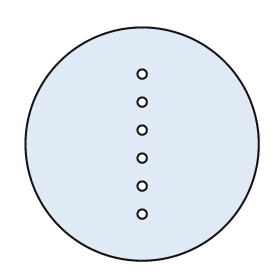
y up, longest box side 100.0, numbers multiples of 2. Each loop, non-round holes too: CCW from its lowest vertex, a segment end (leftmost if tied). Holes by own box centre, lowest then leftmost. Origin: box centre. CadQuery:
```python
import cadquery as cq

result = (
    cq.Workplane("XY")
    .moveTo(0.0, 0.0)
    .circle(50.0)
    .moveTo(0.0, -30.0)
    .circle(2.0)
    .moveTo(0.0, -18.0)
    .circle(2.0)
    .moveTo(0.0, -6.0)
    .circle(2.0)
    .moveTo(0.0, 6.0)
    .circle(2.0)
    .moveTo(0.0, 18.0)
    .circle(2.0)
    .moveTo(0.0, 30.0)
    .circle(2.0)
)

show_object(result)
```